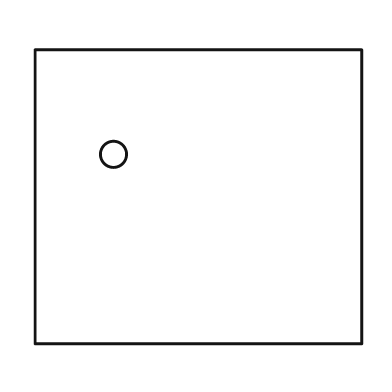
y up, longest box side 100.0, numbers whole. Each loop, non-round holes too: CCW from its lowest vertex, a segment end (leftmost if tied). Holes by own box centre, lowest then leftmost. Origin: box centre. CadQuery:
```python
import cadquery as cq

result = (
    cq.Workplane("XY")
    .moveTo(-50.0, -45.0)
    .lineTo(50.0, -45.0)
    .lineTo(50.0, 45.0)
    .lineTo(-50.0, 45.0)
    .close()
    .moveTo(-26.0, 13.0)
    .circle(4.0)
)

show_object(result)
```